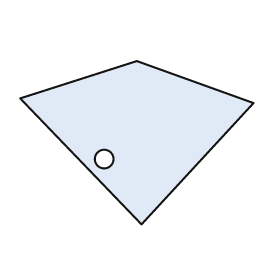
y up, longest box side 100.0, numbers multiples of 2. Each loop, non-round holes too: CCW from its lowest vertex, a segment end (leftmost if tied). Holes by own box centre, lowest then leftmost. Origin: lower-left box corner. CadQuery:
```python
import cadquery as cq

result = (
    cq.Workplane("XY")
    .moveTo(52.0, 0.0)
    .lineTo(100.0, 52.0)
    .lineTo(50.0, 70.0)
    .lineTo(0.0, 54.0)
    .close()
    .moveTo(36.0, 28.0)
    .circle(4.0)
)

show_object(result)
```